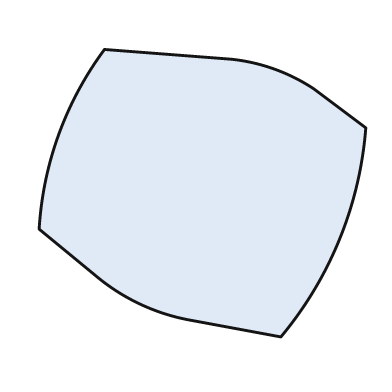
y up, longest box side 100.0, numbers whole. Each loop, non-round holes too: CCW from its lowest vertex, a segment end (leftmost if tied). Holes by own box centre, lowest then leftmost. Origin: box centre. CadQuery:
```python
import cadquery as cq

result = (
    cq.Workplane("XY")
    .moveTo(24.0, -44.0)
    .threePointArc((42.0, -14.0), (50.0, 20.0))
    .lineTo(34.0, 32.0)
    .threePointArc((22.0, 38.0), (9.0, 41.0))
    .lineTo(-30.0, 44.0)
    .threePointArc((-44.0, 18.0), (-50.0, -11.0))
    .lineTo(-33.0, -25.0)
    .threePointArc((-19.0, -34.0), (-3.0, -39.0))
    .close()
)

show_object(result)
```